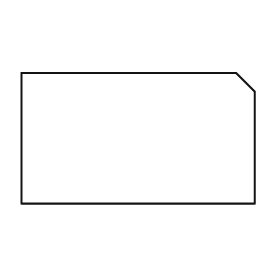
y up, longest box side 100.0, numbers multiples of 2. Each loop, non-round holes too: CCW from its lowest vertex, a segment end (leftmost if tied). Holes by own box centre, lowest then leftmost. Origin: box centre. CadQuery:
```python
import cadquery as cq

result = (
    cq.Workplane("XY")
    .moveTo(-50.0, -28.0)
    .lineTo(50.0, -28.0)
    .lineTo(50.0, 20.0)
    .lineTo(42.0, 28.0)
    .lineTo(-50.0, 28.0)
    .close()
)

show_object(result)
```